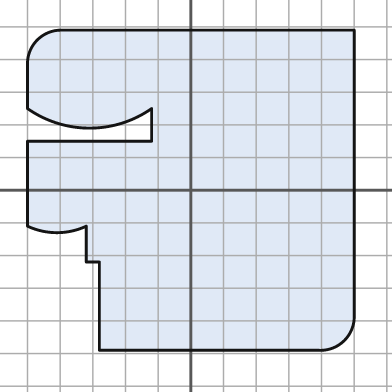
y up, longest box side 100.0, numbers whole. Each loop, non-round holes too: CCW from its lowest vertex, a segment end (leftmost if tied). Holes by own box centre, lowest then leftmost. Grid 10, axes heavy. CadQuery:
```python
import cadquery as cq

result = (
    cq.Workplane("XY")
    .moveTo(-28.0, -49.0)
    .lineTo(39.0, -49.0)
    .threePointArc((47.0, -46.0), (50.0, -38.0))
    .lineTo(50.0, 49.0)
    .lineTo(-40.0, 49.0)
    .threePointArc((-47.0, 46.0), (-50.0, 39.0))
    .lineTo(-50.0, 25.0)
    .threePointArc((-31.0, 19.0), (-12.0, 25.0))
    .lineTo(-12.0, 15.0)
    .lineTo(-50.0, 15.0)
    .lineTo(-50.0, -11.0)
    .threePointArc((-41.0, -13.0), (-32.0, -11.0))
    .lineTo(-32.0, -22.0)
    .lineTo(-28.0, -22.0)
    .close()
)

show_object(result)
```